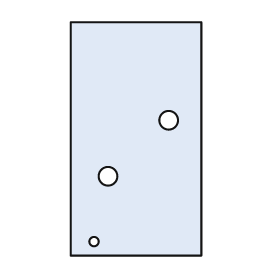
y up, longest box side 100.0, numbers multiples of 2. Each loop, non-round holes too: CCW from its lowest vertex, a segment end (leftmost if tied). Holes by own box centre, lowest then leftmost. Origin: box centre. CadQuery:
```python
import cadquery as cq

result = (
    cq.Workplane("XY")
    .moveTo(-28.0, -50.0)
    .lineTo(28.0, -50.0)
    .lineTo(28.0, 50.0)
    .lineTo(-28.0, 50.0)
    .close()
    .moveTo(-18.0, -44.0)
    .circle(2.0)
    .moveTo(-12.0, -16.0)
    .circle(4.0)
    .moveTo(14.0, 8.0)
    .circle(4.0)
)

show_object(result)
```